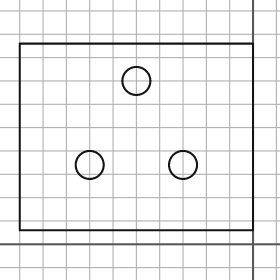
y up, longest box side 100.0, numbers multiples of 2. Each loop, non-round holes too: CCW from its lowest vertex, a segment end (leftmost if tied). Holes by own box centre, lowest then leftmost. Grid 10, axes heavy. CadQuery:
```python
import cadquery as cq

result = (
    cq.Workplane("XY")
    .moveTo(-100.0, 6.0)
    .lineTo(0.0, 6.0)
    .lineTo(0.0, 86.0)
    .lineTo(-100.0, 86.0)
    .close()
    .moveTo(-70.0, 34.0)
    .circle(6.0)
    .moveTo(-30.0, 34.0)
    .circle(6.0)
    .moveTo(-50.0, 70.0)
    .circle(6.0)
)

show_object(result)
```